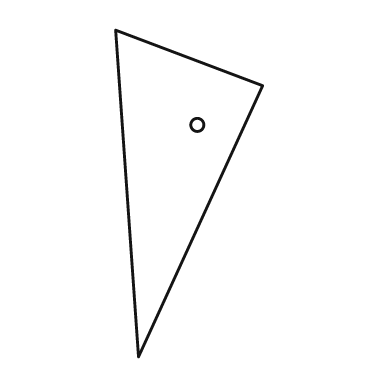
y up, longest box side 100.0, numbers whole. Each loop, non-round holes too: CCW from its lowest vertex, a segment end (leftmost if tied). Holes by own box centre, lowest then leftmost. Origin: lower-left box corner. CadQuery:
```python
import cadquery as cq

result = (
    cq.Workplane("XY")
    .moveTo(7.0, 0.0)
    .lineTo(45.0, 83.0)
    .lineTo(0.0, 100.0)
    .close()
    .moveTo(25.0, 71.0)
    .circle(2.0)
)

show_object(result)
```